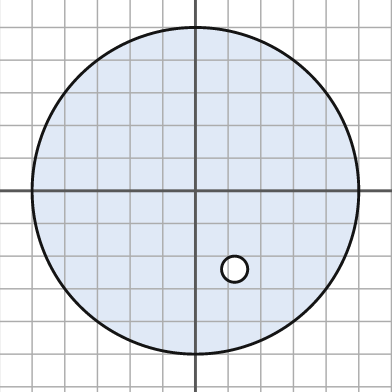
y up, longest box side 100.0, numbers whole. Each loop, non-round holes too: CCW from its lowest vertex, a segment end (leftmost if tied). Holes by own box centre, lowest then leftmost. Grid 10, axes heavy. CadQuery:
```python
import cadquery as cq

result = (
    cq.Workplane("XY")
    .moveTo(0.0, 0.0)
    .circle(50.0)
    .moveTo(12.0, -24.0)
    .circle(4.0)
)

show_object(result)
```